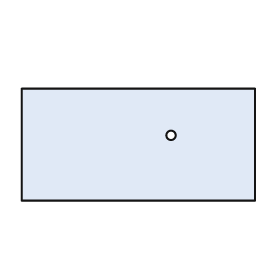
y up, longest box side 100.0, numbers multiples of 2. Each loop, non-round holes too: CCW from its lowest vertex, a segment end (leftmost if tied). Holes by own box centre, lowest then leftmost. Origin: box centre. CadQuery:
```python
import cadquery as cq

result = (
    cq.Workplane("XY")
    .moveTo(-50.0, -24.0)
    .lineTo(50.0, -24.0)
    .lineTo(50.0, 24.0)
    .lineTo(-50.0, 24.0)
    .close()
    .moveTo(14.0, 4.0)
    .circle(2.0)
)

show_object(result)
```